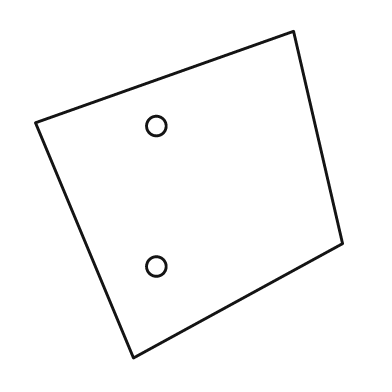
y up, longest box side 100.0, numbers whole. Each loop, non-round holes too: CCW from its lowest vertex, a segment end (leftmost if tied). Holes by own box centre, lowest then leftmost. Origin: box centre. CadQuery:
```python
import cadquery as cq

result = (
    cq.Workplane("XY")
    .moveTo(-17.0, -50.0)
    .lineTo(47.0, -15.0)
    .lineTo(32.0, 50.0)
    .lineTo(-47.0, 22.0)
    .close()
    .moveTo(-10.0, -22.0)
    .circle(3.0)
    .moveTo(-10.0, 21.0)
    .circle(3.0)
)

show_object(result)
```